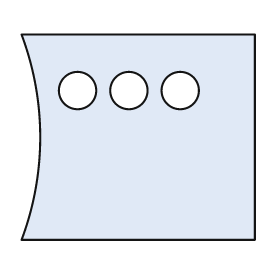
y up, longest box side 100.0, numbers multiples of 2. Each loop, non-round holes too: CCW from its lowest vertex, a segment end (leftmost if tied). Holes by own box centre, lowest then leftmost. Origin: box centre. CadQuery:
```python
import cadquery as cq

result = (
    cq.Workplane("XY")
    .moveTo(-50.0, -44.0)
    .lineTo(50.0, -44.0)
    .lineTo(50.0, 44.0)
    .lineTo(-50.0, 44.0)
    .threePointArc((-42.0, 0.0), (-50.0, -44.0))
    .close()
    .moveTo(-26.0, 20.0)
    .circle(8.0)
    .moveTo(-4.0, 20.0)
    .circle(8.0)
    .moveTo(18.0, 20.0)
    .circle(8.0)
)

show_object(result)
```